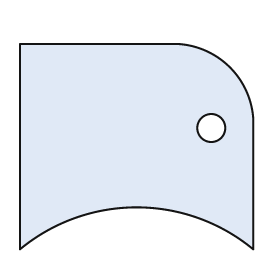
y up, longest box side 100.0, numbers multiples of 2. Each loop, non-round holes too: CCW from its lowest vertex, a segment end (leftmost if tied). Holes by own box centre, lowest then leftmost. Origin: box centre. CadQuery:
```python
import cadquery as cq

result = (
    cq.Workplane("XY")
    .moveTo(-50.0, -44.0)
    .threePointArc((0.0, -26.0), (50.0, -44.0))
    .lineTo(50.0, 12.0)
    .threePointArc((40.0, 34.0), (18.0, 44.0))
    .lineTo(-50.0, 44.0)
    .close()
    .moveTo(32.0, 8.0)
    .circle(6.0)
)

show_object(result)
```